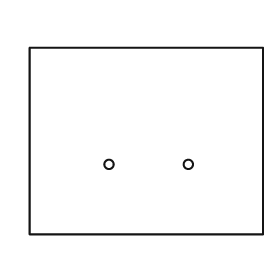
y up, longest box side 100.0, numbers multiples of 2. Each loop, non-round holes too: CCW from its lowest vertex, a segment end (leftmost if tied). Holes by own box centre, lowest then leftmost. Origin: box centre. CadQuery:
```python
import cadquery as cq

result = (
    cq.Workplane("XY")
    .moveTo(-50.0, -40.0)
    .lineTo(50.0, -40.0)
    .lineTo(50.0, 40.0)
    .lineTo(-50.0, 40.0)
    .close()
    .moveTo(-16.0, -10.0)
    .circle(2.0)
    .moveTo(18.0, -10.0)
    .circle(2.0)
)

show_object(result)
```